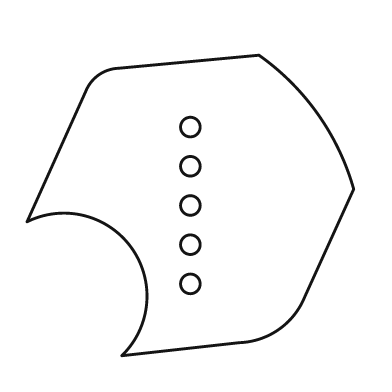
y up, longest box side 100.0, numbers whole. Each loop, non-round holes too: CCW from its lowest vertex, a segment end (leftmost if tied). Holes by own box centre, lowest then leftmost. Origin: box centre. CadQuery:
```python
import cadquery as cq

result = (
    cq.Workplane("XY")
    .moveTo(-21.0, -46.0)
    .lineTo(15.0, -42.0)
    .threePointArc((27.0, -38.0), (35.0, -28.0))
    .lineTo(50.0, 5.0)
    .threePointArc((39.0, 28.0), (21.0, 46.0))
    .lineTo(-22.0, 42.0)
    .threePointArc((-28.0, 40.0), (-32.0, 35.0))
    .lineTo(-50.0, -5.0)
    .threePointArc((-18.0, -13.0), (-21.0, -46.0))
    .close()
    .moveTo(0.0, -24.0)
    .circle(3.0)
    .moveTo(0.0, -12.0)
    .circle(3.0)
    .moveTo(0.0, 0.0)
    .circle(3.0)
    .moveTo(0.0, 12.0)
    .circle(3.0)
    .moveTo(0.0, 24.0)
    .circle(3.0)
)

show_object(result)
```